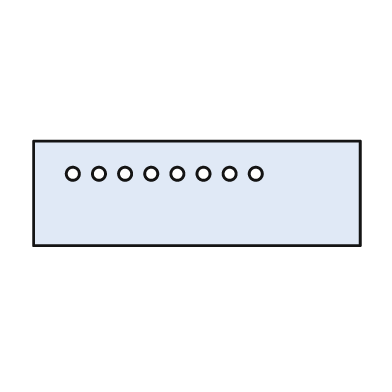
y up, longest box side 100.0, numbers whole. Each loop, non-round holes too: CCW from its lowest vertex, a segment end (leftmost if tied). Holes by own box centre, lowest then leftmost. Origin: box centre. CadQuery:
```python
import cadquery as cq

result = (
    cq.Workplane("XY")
    .moveTo(-50.0, -16.0)
    .lineTo(50.0, -16.0)
    .lineTo(50.0, 16.0)
    .lineTo(-50.0, 16.0)
    .close()
    .moveTo(-38.0, 6.0)
    .circle(2.0)
    .moveTo(-30.0, 6.0)
    .circle(2.0)
    .moveTo(-22.0, 6.0)
    .circle(2.0)
    .moveTo(-14.0, 6.0)
    .circle(2.0)
    .moveTo(-6.0, 6.0)
    .circle(2.0)
    .moveTo(2.0, 6.0)
    .circle(2.0)
    .moveTo(10.0, 6.0)
    .circle(2.0)
    .moveTo(18.0, 6.0)
    .circle(2.0)
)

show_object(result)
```